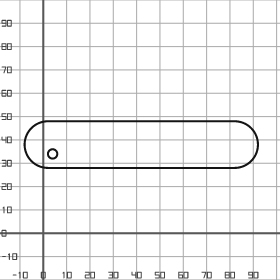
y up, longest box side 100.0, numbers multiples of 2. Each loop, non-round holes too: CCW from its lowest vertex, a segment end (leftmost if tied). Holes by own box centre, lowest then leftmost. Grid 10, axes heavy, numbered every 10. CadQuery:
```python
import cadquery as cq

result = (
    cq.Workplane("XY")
    .moveTo(2.0, 28.0)
    .lineTo(82.0, 28.0)
    .threePointArc((92.0, 38.0), (82.0, 48.0))
    .lineTo(2.0, 48.0)
    .threePointArc((-8.0, 38.0), (2.0, 28.0))
    .close()
    .moveTo(4.0, 34.0)
    .circle(2.0)
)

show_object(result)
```